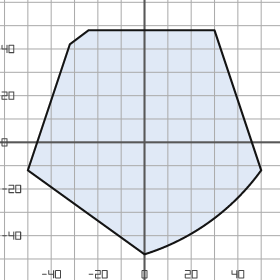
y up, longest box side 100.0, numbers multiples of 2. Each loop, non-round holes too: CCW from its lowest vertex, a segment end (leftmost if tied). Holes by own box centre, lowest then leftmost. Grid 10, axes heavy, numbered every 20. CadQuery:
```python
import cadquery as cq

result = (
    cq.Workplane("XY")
    .moveTo(0.0, -48.0)
    .threePointArc((28.0, -34.0), (50.0, -12.0))
    .lineTo(30.0, 48.0)
    .lineTo(-24.0, 48.0)
    .lineTo(-32.0, 42.0)
    .lineTo(-50.0, -12.0)
    .close()
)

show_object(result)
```